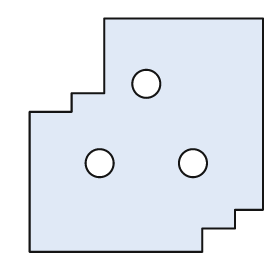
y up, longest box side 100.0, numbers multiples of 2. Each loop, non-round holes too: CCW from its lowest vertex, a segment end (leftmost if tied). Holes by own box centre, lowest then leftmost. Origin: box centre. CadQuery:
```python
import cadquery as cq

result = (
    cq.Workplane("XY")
    .moveTo(-50.0, -50.0)
    .lineTo(24.0, -50.0)
    .lineTo(24.0, -40.0)
    .lineTo(38.0, -40.0)
    .lineTo(38.0, -32.0)
    .lineTo(50.0, -32.0)
    .lineTo(50.0, 50.0)
    .lineTo(-18.0, 50.0)
    .lineTo(-18.0, 18.0)
    .lineTo(-32.0, 18.0)
    .lineTo(-32.0, 10.0)
    .lineTo(-50.0, 10.0)
    .close()
    .moveTo(-20.0, -12.0)
    .circle(6.0)
    .moveTo(20.0, -12.0)
    .circle(6.0)
    .moveTo(0.0, 22.0)
    .circle(6.0)
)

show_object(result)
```